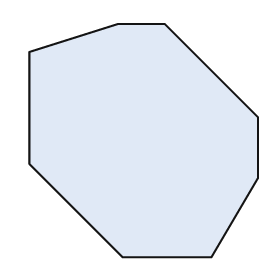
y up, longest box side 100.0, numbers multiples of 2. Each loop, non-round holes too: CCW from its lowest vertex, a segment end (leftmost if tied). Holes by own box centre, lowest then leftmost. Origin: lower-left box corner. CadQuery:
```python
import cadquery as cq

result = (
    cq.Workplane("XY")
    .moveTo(40.0, 0.0)
    .lineTo(78.0, 0.0)
    .lineTo(98.0, 34.0)
    .lineTo(98.0, 60.0)
    .lineTo(58.0, 100.0)
    .lineTo(38.0, 100.0)
    .lineTo(0.0, 88.0)
    .lineTo(0.0, 40.0)
    .close()
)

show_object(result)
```